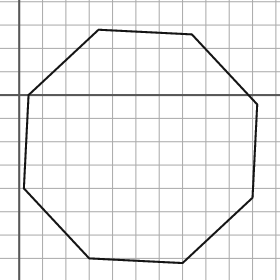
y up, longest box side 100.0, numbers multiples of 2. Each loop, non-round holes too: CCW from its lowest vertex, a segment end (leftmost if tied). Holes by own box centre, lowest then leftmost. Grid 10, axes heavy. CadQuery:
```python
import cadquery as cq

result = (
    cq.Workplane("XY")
    .moveTo(70.0, -72.0)
    .lineTo(100.0, -44.0)
    .lineTo(102.0, -4.0)
    .lineTo(74.0, 26.0)
    .lineTo(34.0, 28.0)
    .lineTo(4.0, 0.0)
    .lineTo(2.0, -40.0)
    .lineTo(30.0, -70.0)
    .close()
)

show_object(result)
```